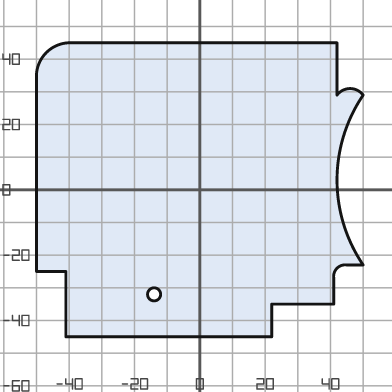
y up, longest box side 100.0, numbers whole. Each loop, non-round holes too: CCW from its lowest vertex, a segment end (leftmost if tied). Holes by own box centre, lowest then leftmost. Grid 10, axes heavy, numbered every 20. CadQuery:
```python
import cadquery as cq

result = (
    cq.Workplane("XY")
    .moveTo(-41.0, -45.0)
    .lineTo(22.0, -45.0)
    .lineTo(22.0, -35.0)
    .lineTo(41.0, -35.0)
    .lineTo(41.0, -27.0)
    .threePointArc((42.0, -24.0), (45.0, -23.0))
    .lineTo(50.0, -23.0)
    .threePointArc((42.0, 3.0), (50.0, 29.0))
    .threePointArc((46.0, 31.0), (42.0, 29.0))
    .lineTo(42.0, 45.0)
    .lineTo(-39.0, 45.0)
    .threePointArc((-47.0, 42.0), (-50.0, 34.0))
    .lineTo(-50.0, -25.0)
    .lineTo(-41.0, -25.0)
    .close()
    .moveTo(-14.0, -32.0)
    .circle(2.0)
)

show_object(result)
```